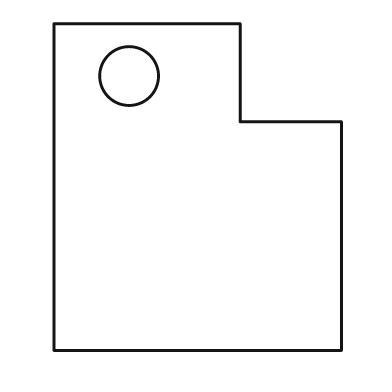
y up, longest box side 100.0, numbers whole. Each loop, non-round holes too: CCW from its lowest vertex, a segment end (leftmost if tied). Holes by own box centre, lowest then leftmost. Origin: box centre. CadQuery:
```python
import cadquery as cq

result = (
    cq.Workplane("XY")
    .moveTo(-44.0, -50.0)
    .lineTo(44.0, -50.0)
    .lineTo(44.0, 20.0)
    .lineTo(13.0, 20.0)
    .lineTo(13.0, 50.0)
    .lineTo(-44.0, 50.0)
    .close()
    .moveTo(-21.0, 34.0)
    .circle(9.0)
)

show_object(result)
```